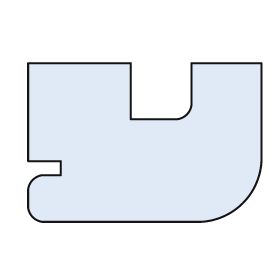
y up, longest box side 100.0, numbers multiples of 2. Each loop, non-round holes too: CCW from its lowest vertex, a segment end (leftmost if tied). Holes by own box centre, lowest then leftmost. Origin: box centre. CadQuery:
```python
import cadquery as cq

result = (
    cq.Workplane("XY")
    .moveTo(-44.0, -34.0)
    .lineTo(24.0, -34.0)
    .threePointArc((42.0, -26.0), (50.0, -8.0))
    .lineTo(50.0, 34.0)
    .lineTo(20.0, 34.0)
    .lineTo(20.0, 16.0)
    .threePointArc((18.0, 12.0), (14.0, 10.0))
    .lineTo(-6.0, 10.0)
    .lineTo(-6.0, 34.0)
    .lineTo(-50.0, 34.0)
    .lineTo(-50.0, -8.0)
    .lineTo(-36.0, -8.0)
    .lineTo(-36.0, -14.0)
    .lineTo(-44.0, -14.0)
    .threePointArc((-48.0, -16.0), (-50.0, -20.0))
    .lineTo(-50.0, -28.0)
    .threePointArc((-48.0, -32.0), (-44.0, -34.0))
    .close()
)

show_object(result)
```